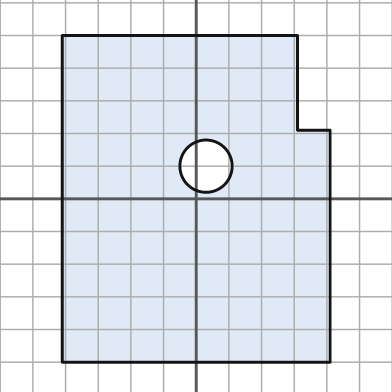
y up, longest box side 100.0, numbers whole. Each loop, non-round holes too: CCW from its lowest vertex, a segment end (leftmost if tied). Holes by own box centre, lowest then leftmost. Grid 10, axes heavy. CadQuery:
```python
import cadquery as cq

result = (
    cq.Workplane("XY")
    .moveTo(-41.0, -50.0)
    .lineTo(41.0, -50.0)
    .lineTo(41.0, 21.0)
    .lineTo(31.0, 21.0)
    .lineTo(31.0, 50.0)
    .lineTo(-41.0, 50.0)
    .close()
    .moveTo(3.0, 10.0)
    .circle(8.0)
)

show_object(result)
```